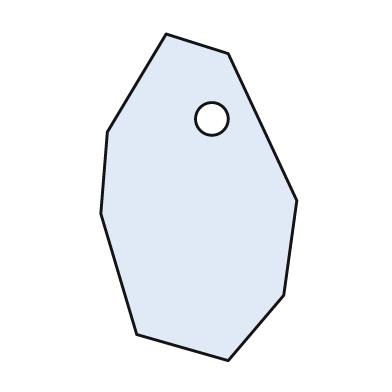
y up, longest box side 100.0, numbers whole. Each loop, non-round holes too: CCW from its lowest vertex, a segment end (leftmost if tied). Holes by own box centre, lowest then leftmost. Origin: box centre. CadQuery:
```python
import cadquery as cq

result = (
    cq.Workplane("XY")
    .moveTo(9.0, -50.0)
    .lineTo(26.0, -30.0)
    .lineTo(30.0, -1.0)
    .lineTo(9.0, 44.0)
    .lineTo(-10.0, 50.0)
    .lineTo(-28.0, 20.0)
    .lineTo(-30.0, -5.0)
    .lineTo(-19.0, -42.0)
    .close()
    .moveTo(4.0, 24.0)
    .circle(5.0)
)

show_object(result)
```